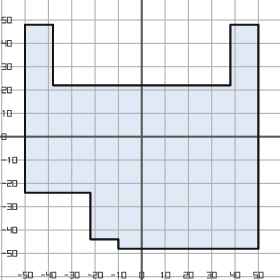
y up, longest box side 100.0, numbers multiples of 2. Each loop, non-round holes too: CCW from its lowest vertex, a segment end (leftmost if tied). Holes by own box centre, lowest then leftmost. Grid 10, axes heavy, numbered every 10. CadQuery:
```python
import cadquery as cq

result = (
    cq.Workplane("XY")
    .moveTo(-10.0, -48.0)
    .lineTo(50.0, -48.0)
    .lineTo(50.0, 48.0)
    .lineTo(38.0, 48.0)
    .lineTo(38.0, 22.0)
    .lineTo(-38.0, 22.0)
    .lineTo(-38.0, 48.0)
    .lineTo(-50.0, 48.0)
    .lineTo(-50.0, -24.0)
    .lineTo(-22.0, -24.0)
    .lineTo(-22.0, -44.0)
    .lineTo(-10.0, -44.0)
    .close()
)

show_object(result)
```